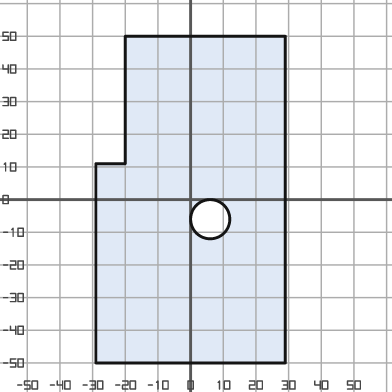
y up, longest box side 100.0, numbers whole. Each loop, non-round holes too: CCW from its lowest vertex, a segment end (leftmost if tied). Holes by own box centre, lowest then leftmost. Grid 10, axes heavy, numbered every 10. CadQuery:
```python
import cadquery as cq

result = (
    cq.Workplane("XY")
    .moveTo(-29.0, -50.0)
    .lineTo(29.0, -50.0)
    .lineTo(29.0, 50.0)
    .lineTo(-20.0, 50.0)
    .lineTo(-20.0, 11.0)
    .lineTo(-29.0, 11.0)
    .close()
    .moveTo(6.0, -6.0)
    .circle(6.0)
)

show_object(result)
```